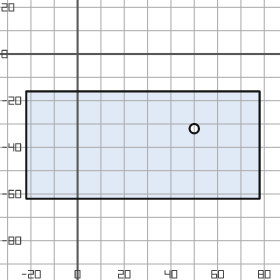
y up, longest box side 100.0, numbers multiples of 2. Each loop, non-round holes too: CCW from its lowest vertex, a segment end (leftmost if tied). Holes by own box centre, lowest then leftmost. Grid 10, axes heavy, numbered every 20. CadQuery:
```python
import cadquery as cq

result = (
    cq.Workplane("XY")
    .moveTo(-22.0, -62.0)
    .lineTo(78.0, -62.0)
    .lineTo(78.0, -16.0)
    .lineTo(-22.0, -16.0)
    .close()
    .moveTo(50.0, -32.0)
    .circle(2.0)
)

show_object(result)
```